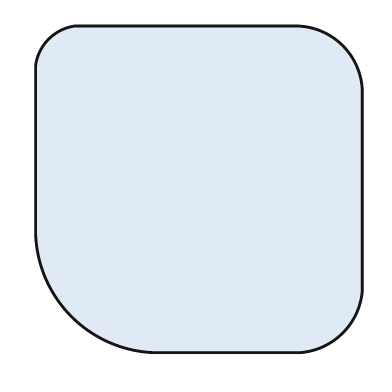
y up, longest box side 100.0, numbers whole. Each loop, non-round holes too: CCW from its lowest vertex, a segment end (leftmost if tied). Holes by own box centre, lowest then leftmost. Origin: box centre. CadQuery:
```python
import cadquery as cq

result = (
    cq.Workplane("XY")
    .moveTo(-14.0, -50.0)
    .lineTo(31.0, -50.0)
    .threePointArc((44.0, -44.0), (50.0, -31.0))
    .lineTo(50.0, 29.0)
    .threePointArc((44.0, 44.0), (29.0, 50.0))
    .lineTo(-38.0, 50.0)
    .threePointArc((-46.0, 46.0), (-50.0, 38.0))
    .lineTo(-50.0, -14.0)
    .threePointArc((-39.0, -39.0), (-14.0, -50.0))
    .close()
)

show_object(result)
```